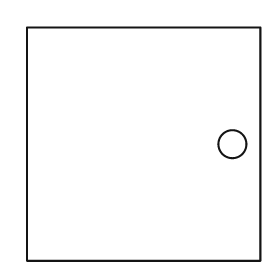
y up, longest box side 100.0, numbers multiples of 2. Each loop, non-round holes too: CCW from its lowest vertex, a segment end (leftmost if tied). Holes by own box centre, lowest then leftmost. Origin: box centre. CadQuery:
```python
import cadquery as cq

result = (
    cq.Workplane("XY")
    .moveTo(-50.0, -50.0)
    .lineTo(50.0, -50.0)
    .lineTo(50.0, 50.0)
    .lineTo(-50.0, 50.0)
    .close()
    .moveTo(38.0, 0.0)
    .circle(6.0)
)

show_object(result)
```